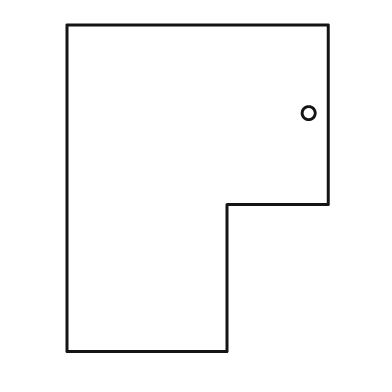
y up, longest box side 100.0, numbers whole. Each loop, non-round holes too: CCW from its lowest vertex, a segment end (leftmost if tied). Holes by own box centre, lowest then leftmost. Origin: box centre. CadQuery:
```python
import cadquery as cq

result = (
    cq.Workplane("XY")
    .moveTo(-40.0, -50.0)
    .lineTo(9.0, -50.0)
    .lineTo(9.0, -5.0)
    .lineTo(40.0, -5.0)
    .lineTo(40.0, 50.0)
    .lineTo(-40.0, 50.0)
    .close()
    .moveTo(34.0, 23.0)
    .circle(2.0)
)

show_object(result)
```